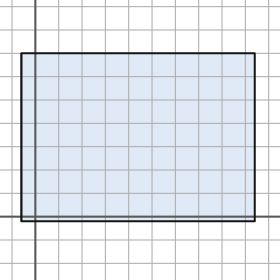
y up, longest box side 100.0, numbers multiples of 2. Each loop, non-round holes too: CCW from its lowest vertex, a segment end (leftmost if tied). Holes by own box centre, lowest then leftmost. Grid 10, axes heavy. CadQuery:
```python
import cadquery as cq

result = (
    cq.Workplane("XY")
    .moveTo(-6.0, -2.0)
    .lineTo(94.0, -2.0)
    .lineTo(94.0, 70.0)
    .lineTo(-6.0, 70.0)
    .close()
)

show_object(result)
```